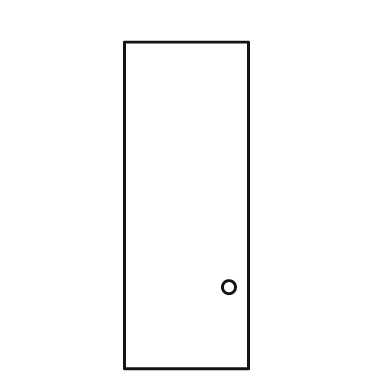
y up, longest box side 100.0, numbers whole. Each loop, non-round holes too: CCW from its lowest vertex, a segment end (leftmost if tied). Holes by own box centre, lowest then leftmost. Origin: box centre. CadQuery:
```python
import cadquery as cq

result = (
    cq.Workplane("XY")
    .moveTo(-19.0, -50.0)
    .lineTo(19.0, -50.0)
    .lineTo(19.0, 50.0)
    .lineTo(-19.0, 50.0)
    .close()
    .moveTo(13.0, -25.0)
    .circle(2.0)
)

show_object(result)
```